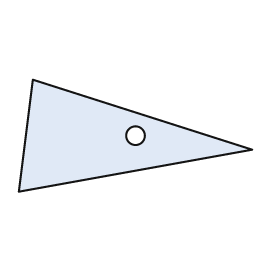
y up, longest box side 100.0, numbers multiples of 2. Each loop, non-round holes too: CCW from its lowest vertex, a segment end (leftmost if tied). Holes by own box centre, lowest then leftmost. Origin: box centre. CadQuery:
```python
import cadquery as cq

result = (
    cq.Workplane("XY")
    .moveTo(-50.0, -24.0)
    .lineTo(50.0, -6.0)
    .lineTo(-44.0, 24.0)
    .close()
    .moveTo(0.0, 0.0)
    .circle(4.0)
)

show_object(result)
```